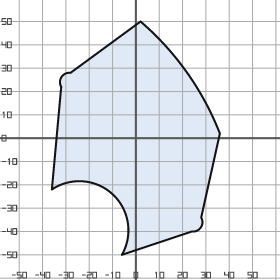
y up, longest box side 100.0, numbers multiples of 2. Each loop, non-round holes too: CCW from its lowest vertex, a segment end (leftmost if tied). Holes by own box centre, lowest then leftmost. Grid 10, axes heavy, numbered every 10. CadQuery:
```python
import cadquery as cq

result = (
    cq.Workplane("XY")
    .moveTo(-6.0, -50.0)
    .lineTo(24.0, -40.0)
    .threePointArc((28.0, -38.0), (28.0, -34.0))
    .lineTo(36.0, 2.0)
    .threePointArc((22.0, 28.0), (2.0, 50.0))
    .lineTo(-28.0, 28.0)
    .threePointArc((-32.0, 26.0), (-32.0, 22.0))
    .lineTo(-36.0, -22.0)
    .threePointArc((-10.0, -24.0), (-6.0, -50.0))
    .close()
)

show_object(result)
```